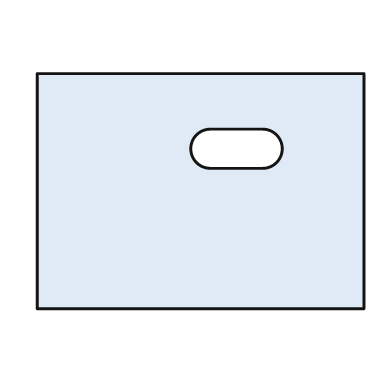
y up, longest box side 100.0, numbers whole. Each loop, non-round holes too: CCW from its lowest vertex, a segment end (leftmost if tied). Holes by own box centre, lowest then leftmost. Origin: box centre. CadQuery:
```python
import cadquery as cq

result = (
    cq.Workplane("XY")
    .moveTo(-50.0, -36.0)
    .lineTo(50.0, -36.0)
    .lineTo(50.0, 36.0)
    .lineTo(-50.0, 36.0)
    .close()
    .moveTo(3.0, 7.0)
    .lineTo(19.0, 7.0)
    .threePointArc((25.0, 13.0), (19.0, 19.0))
    .lineTo(3.0, 19.0)
    .threePointArc((-3.0, 13.0), (3.0, 7.0))
    .close()
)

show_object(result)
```